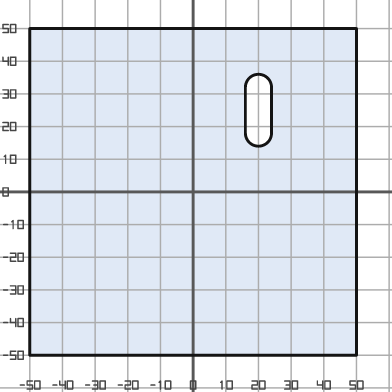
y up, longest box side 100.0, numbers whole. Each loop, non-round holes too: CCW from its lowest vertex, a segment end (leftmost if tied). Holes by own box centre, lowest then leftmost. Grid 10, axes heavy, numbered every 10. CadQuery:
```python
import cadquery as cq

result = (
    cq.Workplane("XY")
    .moveTo(-50.0, -50.0)
    .lineTo(50.0, -50.0)
    .lineTo(50.0, 50.0)
    .lineTo(-50.0, 50.0)
    .close()
    .moveTo(16.0, 18.0)
    .threePointArc((20.0, 14.0), (24.0, 18.0))
    .lineTo(24.0, 32.0)
    .threePointArc((20.0, 36.0), (16.0, 32.0))
    .close()
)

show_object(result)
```